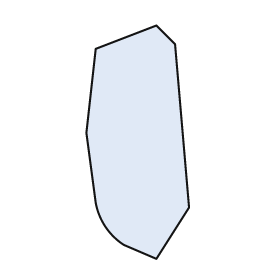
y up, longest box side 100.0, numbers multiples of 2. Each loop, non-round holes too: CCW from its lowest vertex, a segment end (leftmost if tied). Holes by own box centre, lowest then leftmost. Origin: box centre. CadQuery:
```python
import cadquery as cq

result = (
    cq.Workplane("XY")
    .moveTo(8.0, -50.0)
    .lineTo(22.0, -28.0)
    .lineTo(16.0, 42.0)
    .lineTo(8.0, 50.0)
    .lineTo(-18.0, 40.0)
    .lineTo(-22.0, 4.0)
    .lineTo(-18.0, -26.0)
    .threePointArc((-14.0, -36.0), (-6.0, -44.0))
    .close()
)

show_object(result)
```